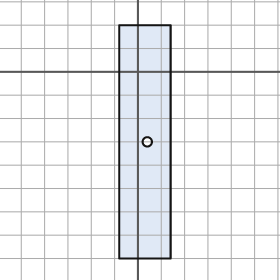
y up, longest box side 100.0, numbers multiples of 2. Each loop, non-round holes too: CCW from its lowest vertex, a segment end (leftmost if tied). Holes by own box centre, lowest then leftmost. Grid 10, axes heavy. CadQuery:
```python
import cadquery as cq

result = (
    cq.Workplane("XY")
    .moveTo(-8.0, -80.0)
    .lineTo(14.0, -80.0)
    .lineTo(14.0, 20.0)
    .lineTo(-8.0, 20.0)
    .close()
    .moveTo(4.0, -30.0)
    .circle(2.0)
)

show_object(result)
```